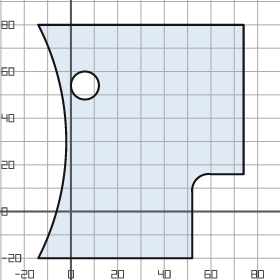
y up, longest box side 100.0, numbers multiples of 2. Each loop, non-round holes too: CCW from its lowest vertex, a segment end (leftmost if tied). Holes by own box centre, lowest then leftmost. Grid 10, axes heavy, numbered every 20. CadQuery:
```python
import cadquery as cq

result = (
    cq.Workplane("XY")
    .moveTo(-14.0, -20.0)
    .lineTo(52.0, -20.0)
    .lineTo(52.0, 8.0)
    .threePointArc((54.0, 14.0), (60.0, 16.0))
    .lineTo(74.0, 16.0)
    .lineTo(74.0, 80.0)
    .lineTo(-14.0, 80.0)
    .threePointArc((-2.0, 30.0), (-14.0, -20.0))
    .close()
    .moveTo(6.0, 54.0)
    .circle(6.0)
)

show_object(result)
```